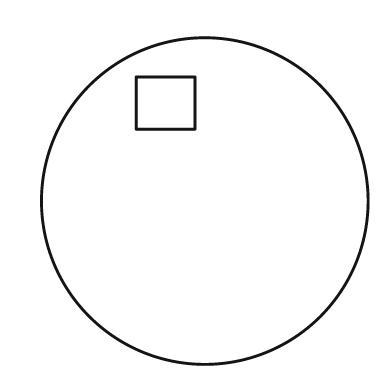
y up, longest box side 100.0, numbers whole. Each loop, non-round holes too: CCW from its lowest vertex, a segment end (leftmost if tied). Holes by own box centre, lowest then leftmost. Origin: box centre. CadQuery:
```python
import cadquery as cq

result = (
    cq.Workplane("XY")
    .moveTo(0.0, 0.0)
    .circle(50.0)
    .moveTo(-21.0, 22.0)
    .lineTo(-3.0, 22.0)
    .lineTo(-3.0, 38.0)
    .lineTo(-21.0, 38.0)
    .close()
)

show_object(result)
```